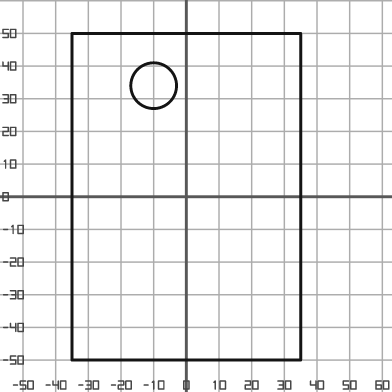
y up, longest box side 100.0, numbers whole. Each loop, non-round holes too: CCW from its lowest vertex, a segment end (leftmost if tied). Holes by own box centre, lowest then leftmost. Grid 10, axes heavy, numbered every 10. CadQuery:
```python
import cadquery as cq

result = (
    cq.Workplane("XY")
    .moveTo(-35.0, -50.0)
    .lineTo(35.0, -50.0)
    .lineTo(35.0, 50.0)
    .lineTo(-35.0, 50.0)
    .close()
    .moveTo(-10.0, 34.0)
    .circle(7.0)
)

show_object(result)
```